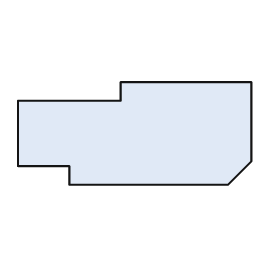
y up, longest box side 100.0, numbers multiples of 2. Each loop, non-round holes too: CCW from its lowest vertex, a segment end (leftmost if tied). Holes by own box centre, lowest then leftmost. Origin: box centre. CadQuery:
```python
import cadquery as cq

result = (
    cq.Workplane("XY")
    .moveTo(-28.0, -22.0)
    .lineTo(40.0, -22.0)
    .lineTo(50.0, -12.0)
    .lineTo(50.0, 22.0)
    .lineTo(-6.0, 22.0)
    .lineTo(-6.0, 14.0)
    .lineTo(-50.0, 14.0)
    .lineTo(-50.0, -14.0)
    .lineTo(-28.0, -14.0)
    .close()
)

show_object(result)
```